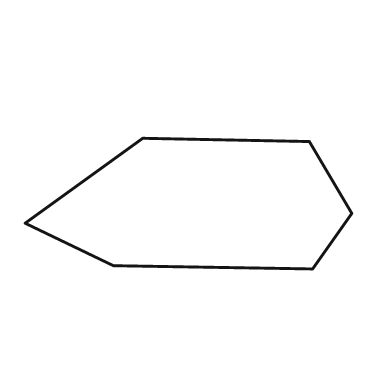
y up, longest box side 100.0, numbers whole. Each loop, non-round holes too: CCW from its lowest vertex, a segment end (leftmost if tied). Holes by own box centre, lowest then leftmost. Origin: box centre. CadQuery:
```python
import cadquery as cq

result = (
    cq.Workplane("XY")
    .moveTo(38.0, -20.0)
    .lineTo(50.0, -3.0)
    .lineTo(37.0, 19.0)
    .lineTo(-14.0, 20.0)
    .lineTo(-50.0, -6.0)
    .lineTo(-23.0, -19.0)
    .close()
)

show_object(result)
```